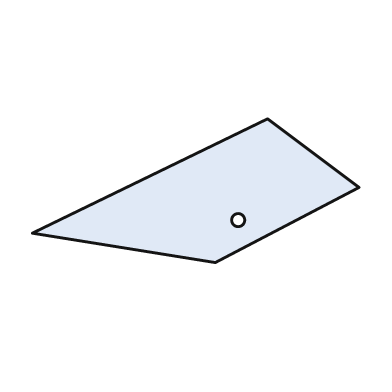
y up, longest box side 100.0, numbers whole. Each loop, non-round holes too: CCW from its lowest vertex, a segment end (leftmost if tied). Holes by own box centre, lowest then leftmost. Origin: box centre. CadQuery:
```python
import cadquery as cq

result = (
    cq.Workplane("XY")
    .moveTo(6.0, -22.0)
    .lineTo(50.0, 1.0)
    .lineTo(22.0, 22.0)
    .lineTo(-50.0, -13.0)
    .close()
    .moveTo(13.0, -9.0)
    .circle(2.0)
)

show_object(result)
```